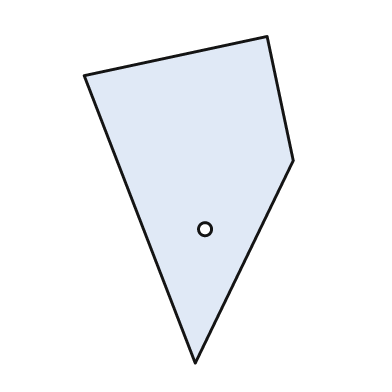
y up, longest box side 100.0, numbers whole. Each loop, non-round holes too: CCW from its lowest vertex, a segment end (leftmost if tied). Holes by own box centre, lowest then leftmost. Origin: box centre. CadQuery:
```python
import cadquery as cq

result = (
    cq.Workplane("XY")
    .moveTo(2.0, -50.0)
    .lineTo(32.0, 12.0)
    .lineTo(24.0, 50.0)
    .lineTo(-32.0, 38.0)
    .close()
    .moveTo(5.0, -9.0)
    .circle(2.0)
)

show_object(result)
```